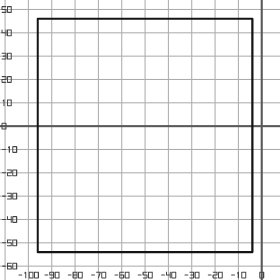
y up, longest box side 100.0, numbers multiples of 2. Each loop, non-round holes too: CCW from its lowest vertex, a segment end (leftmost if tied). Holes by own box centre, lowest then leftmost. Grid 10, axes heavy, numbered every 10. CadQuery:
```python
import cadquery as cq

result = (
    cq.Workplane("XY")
    .moveTo(-96.0, -54.0)
    .lineTo(-4.0, -54.0)
    .lineTo(-4.0, 46.0)
    .lineTo(-96.0, 46.0)
    .close()
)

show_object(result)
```